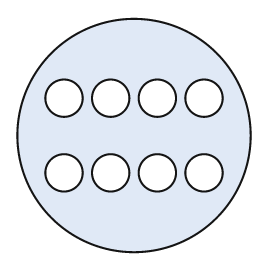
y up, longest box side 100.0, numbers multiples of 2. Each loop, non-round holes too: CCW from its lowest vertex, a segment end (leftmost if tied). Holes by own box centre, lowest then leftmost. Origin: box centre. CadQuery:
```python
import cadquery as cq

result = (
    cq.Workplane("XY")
    .moveTo(0.0, 0.0)
    .circle(50.0)
    .moveTo(-30.0, -16.0)
    .circle(8.0)
    .moveTo(-10.0, -16.0)
    .circle(8.0)
    .moveTo(10.0, -16.0)
    .circle(8.0)
    .moveTo(30.0, -16.0)
    .circle(8.0)
    .moveTo(-30.0, 16.0)
    .circle(8.0)
    .moveTo(-10.0, 16.0)
    .circle(8.0)
    .moveTo(10.0, 16.0)
    .circle(8.0)
    .moveTo(30.0, 16.0)
    .circle(8.0)
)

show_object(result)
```